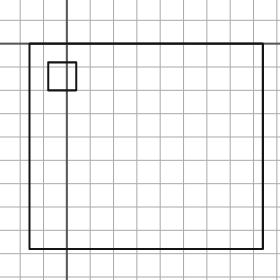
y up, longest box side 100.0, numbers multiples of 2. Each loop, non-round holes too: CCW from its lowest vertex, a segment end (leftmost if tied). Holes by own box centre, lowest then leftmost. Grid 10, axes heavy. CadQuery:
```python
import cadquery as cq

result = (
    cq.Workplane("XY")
    .moveTo(-16.0, -88.0)
    .lineTo(84.0, -88.0)
    .lineTo(84.0, 0.0)
    .lineTo(-16.0, 0.0)
    .close()
    .moveTo(-8.0, -20.0)
    .lineTo(4.0, -20.0)
    .lineTo(4.0, -8.0)
    .lineTo(-8.0, -8.0)
    .close()
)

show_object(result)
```